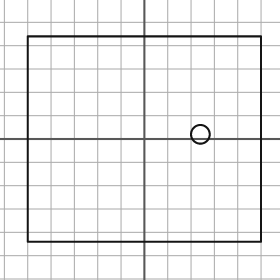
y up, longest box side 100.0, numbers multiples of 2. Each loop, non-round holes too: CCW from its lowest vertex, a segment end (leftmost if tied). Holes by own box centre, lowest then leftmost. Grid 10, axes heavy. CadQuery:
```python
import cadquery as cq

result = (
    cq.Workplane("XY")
    .moveTo(-50.0, -44.0)
    .lineTo(50.0, -44.0)
    .lineTo(50.0, 44.0)
    .lineTo(-50.0, 44.0)
    .close()
    .moveTo(24.0, 2.0)
    .circle(4.0)
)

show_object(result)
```